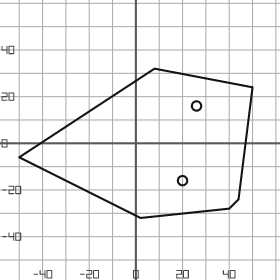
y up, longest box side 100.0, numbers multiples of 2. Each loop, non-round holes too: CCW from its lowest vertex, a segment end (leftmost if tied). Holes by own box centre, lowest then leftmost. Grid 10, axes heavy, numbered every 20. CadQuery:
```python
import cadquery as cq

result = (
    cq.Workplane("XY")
    .moveTo(2.0, -32.0)
    .lineTo(40.0, -28.0)
    .lineTo(44.0, -24.0)
    .lineTo(50.0, 24.0)
    .lineTo(8.0, 32.0)
    .lineTo(-50.0, -6.0)
    .close()
    .moveTo(20.0, -16.0)
    .circle(2.0)
    .moveTo(26.0, 16.0)
    .circle(2.0)
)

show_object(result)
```